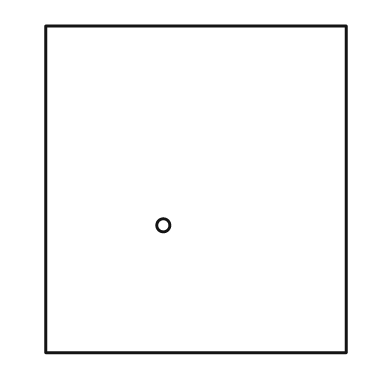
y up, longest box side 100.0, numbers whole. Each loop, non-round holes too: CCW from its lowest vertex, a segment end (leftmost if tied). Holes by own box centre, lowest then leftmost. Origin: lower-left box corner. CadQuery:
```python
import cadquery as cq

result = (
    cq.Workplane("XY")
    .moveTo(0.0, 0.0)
    .lineTo(92.0, 0.0)
    .lineTo(92.0, 100.0)
    .lineTo(0.0, 100.0)
    .close()
    .moveTo(36.0, 39.0)
    .circle(2.0)
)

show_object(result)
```